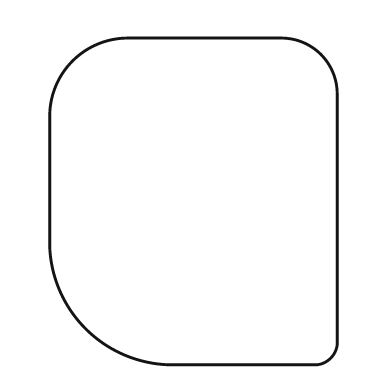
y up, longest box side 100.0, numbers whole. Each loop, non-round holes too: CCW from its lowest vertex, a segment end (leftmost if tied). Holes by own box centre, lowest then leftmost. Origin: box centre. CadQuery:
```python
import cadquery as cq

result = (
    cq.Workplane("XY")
    .moveTo(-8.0, -50.0)
    .lineTo(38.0, -50.0)
    .threePointArc((42.0, -48.0), (44.0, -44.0))
    .lineTo(44.0, 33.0)
    .threePointArc((39.0, 45.0), (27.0, 50.0))
    .lineTo(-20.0, 50.0)
    .threePointArc((-37.0, 43.0), (-44.0, 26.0))
    .lineTo(-44.0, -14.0)
    .threePointArc((-33.0, -39.0), (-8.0, -50.0))
    .close()
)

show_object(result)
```